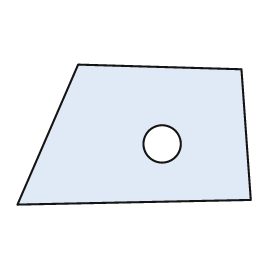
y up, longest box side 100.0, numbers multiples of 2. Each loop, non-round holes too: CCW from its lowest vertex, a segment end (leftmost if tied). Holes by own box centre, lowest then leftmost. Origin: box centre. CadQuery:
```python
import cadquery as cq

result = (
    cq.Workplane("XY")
    .moveTo(-50.0, -30.0)
    .lineTo(50.0, -28.0)
    .lineTo(46.0, 28.0)
    .lineTo(-24.0, 30.0)
    .close()
    .moveTo(12.0, -4.0)
    .circle(8.0)
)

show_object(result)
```